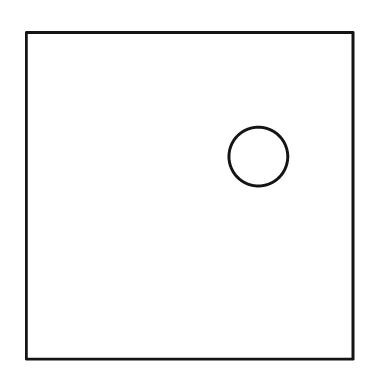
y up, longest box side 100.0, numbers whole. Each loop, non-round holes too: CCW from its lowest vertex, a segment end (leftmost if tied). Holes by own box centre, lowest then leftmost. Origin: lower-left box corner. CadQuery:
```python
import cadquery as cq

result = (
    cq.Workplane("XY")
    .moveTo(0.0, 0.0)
    .lineTo(100.0, 0.0)
    .lineTo(100.0, 100.0)
    .lineTo(0.0, 100.0)
    .close()
    .moveTo(71.0, 62.0)
    .circle(9.0)
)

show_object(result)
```